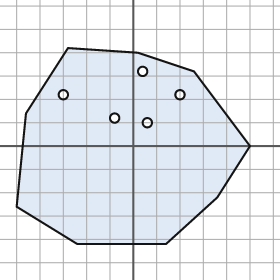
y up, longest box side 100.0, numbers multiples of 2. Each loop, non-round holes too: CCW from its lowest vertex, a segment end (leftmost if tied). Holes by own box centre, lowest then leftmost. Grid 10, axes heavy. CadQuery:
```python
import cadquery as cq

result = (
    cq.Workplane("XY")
    .moveTo(-24.0, -42.0)
    .lineTo(14.0, -42.0)
    .lineTo(36.0, -22.0)
    .lineTo(50.0, 0.0)
    .lineTo(26.0, 32.0)
    .lineTo(2.0, 40.0)
    .lineTo(-28.0, 42.0)
    .lineTo(-46.0, 14.0)
    .lineTo(-50.0, -26.0)
    .close()
    .moveTo(6.0, 10.0)
    .circle(2.0)
    .moveTo(-8.0, 12.0)
    .circle(2.0)
    .moveTo(-30.0, 22.0)
    .circle(2.0)
    .moveTo(20.0, 22.0)
    .circle(2.0)
    .moveTo(4.0, 32.0)
    .circle(2.0)
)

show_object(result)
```